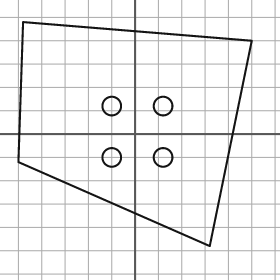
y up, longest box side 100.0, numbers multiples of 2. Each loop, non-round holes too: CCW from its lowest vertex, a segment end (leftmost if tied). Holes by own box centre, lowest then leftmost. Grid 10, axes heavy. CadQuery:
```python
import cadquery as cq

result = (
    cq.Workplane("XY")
    .moveTo(32.0, -48.0)
    .lineTo(50.0, 40.0)
    .lineTo(-48.0, 48.0)
    .lineTo(-50.0, -12.0)
    .close()
    .moveTo(-10.0, -10.0)
    .circle(4.0)
    .moveTo(12.0, -10.0)
    .circle(4.0)
    .moveTo(-10.0, 12.0)
    .circle(4.0)
    .moveTo(12.0, 12.0)
    .circle(4.0)
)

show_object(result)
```